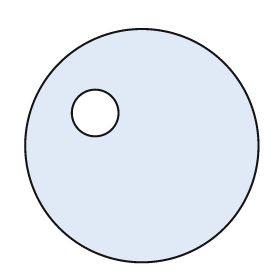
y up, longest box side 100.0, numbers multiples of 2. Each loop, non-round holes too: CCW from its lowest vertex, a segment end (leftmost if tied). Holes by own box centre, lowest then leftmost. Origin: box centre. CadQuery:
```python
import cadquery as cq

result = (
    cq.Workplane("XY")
    .moveTo(0.0, 0.0)
    .circle(50.0)
    .moveTo(-20.0, 14.0)
    .circle(10.0)
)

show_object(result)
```